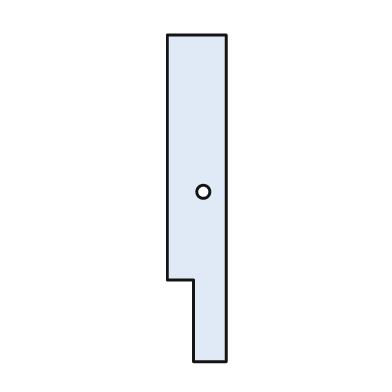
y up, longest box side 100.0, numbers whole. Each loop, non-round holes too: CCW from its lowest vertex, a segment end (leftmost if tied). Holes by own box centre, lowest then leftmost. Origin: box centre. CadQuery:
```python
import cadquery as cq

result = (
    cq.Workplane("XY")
    .moveTo(-1.0, -50.0)
    .lineTo(9.0, -50.0)
    .lineTo(9.0, 50.0)
    .lineTo(-9.0, 50.0)
    .lineTo(-9.0, -25.0)
    .lineTo(-1.0, -25.0)
    .close()
    .moveTo(2.0, 2.0)
    .circle(2.0)
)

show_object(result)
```